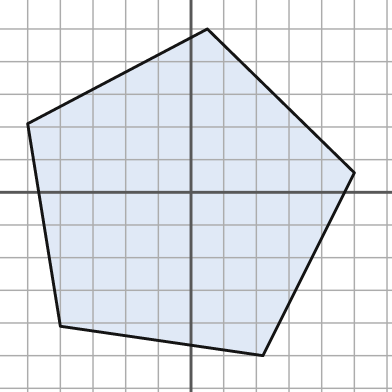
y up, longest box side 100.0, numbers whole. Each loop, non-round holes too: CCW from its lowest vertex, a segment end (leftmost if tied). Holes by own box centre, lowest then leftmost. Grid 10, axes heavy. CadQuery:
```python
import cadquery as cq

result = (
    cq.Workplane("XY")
    .moveTo(22.0, -50.0)
    .lineTo(50.0, 6.0)
    .lineTo(5.0, 50.0)
    .lineTo(-50.0, 21.0)
    .lineTo(-40.0, -41.0)
    .close()
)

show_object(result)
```